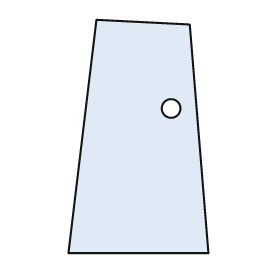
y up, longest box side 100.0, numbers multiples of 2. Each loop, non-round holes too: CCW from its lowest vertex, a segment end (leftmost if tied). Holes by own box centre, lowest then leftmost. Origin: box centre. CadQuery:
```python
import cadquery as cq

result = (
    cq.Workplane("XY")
    .moveTo(-30.0, -50.0)
    .lineTo(30.0, -50.0)
    .lineTo(22.0, 48.0)
    .lineTo(-18.0, 50.0)
    .close()
    .moveTo(14.0, 12.0)
    .circle(4.0)
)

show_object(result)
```